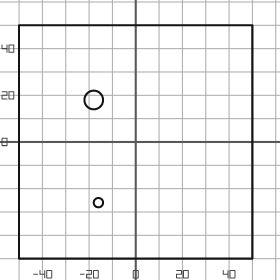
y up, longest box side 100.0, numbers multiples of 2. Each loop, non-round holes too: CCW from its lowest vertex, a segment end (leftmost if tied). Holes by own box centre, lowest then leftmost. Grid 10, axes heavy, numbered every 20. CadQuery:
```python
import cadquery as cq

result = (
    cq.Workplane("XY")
    .moveTo(-50.0, -50.0)
    .lineTo(50.0, -50.0)
    .lineTo(50.0, 50.0)
    .lineTo(-50.0, 50.0)
    .close()
    .moveTo(-16.0, -26.0)
    .circle(2.0)
    .moveTo(-18.0, 18.0)
    .circle(4.0)
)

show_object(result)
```